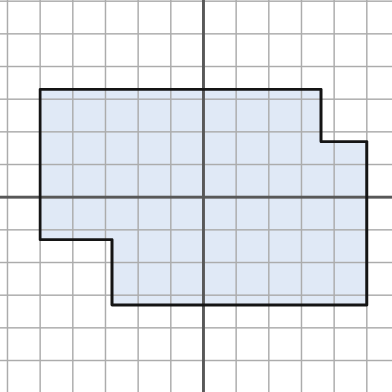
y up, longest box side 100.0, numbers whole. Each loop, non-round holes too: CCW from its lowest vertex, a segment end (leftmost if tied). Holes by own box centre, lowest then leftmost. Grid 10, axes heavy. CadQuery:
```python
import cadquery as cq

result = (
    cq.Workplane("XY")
    .moveTo(-28.0, -33.0)
    .lineTo(50.0, -33.0)
    .lineTo(50.0, 17.0)
    .lineTo(36.0, 17.0)
    .lineTo(36.0, 33.0)
    .lineTo(-50.0, 33.0)
    .lineTo(-50.0, -13.0)
    .lineTo(-28.0, -13.0)
    .close()
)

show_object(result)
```